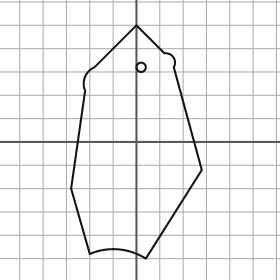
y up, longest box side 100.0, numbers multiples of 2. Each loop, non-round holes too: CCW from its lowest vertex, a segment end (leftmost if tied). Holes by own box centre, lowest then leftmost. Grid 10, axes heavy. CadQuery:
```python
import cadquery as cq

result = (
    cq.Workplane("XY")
    .moveTo(4.0, -50.0)
    .lineTo(28.0, -12.0)
    .lineTo(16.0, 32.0)
    .threePointArc((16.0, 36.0), (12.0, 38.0))
    .lineTo(0.0, 50.0)
    .lineTo(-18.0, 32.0)
    .threePointArc((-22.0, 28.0), (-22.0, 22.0))
    .lineTo(-28.0, -20.0)
    .lineTo(-20.0, -48.0)
    .threePointArc((-8.0, -46.0), (4.0, -50.0))
    .close()
    .moveTo(2.0, 32.0)
    .circle(2.0)
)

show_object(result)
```